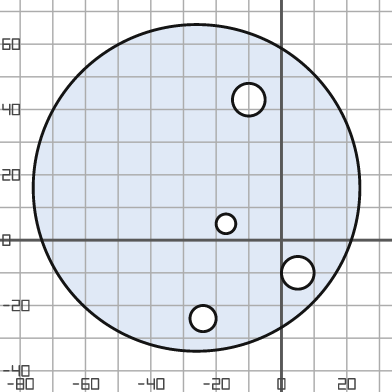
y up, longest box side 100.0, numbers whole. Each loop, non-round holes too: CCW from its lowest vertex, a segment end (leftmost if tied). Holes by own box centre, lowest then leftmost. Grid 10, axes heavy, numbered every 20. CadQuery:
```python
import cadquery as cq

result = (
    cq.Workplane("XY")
    .moveTo(-26.0, 16.0)
    .circle(50.0)
    .moveTo(-24.0, -24.0)
    .circle(4.0)
    .moveTo(5.0, -10.0)
    .circle(5.0)
    .moveTo(-17.0, 5.0)
    .circle(3.0)
    .moveTo(-10.0, 43.0)
    .circle(5.0)
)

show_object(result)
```